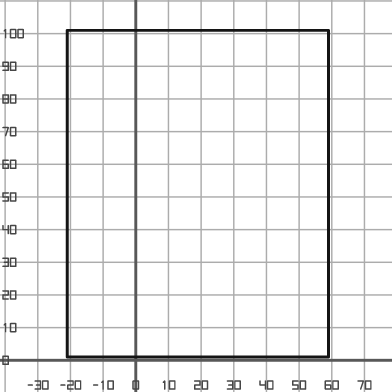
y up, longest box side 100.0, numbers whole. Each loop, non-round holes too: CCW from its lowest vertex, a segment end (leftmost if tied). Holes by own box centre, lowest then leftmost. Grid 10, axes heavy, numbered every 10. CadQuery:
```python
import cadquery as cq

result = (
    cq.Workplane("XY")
    .moveTo(-21.0, 1.0)
    .lineTo(59.0, 1.0)
    .lineTo(59.0, 101.0)
    .lineTo(-21.0, 101.0)
    .close()
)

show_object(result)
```